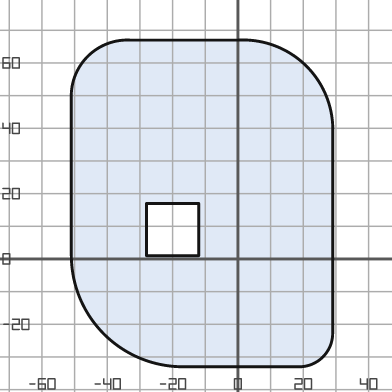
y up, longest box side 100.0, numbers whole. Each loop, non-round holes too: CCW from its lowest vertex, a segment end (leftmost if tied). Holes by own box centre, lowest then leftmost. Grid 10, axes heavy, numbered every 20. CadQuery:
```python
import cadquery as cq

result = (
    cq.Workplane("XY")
    .moveTo(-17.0, -33.0)
    .lineTo(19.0, -33.0)
    .threePointArc((26.0, -30.0), (29.0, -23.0))
    .lineTo(29.0, 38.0)
    .threePointArc((21.0, 59.0), (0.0, 67.0))
    .lineTo(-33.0, 67.0)
    .threePointArc((-46.0, 62.0), (-51.0, 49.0))
    .lineTo(-51.0, 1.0)
    .threePointArc((-41.0, -23.0), (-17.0, -33.0))
    .close()
    .moveTo(-28.0, 1.0)
    .lineTo(-12.0, 1.0)
    .lineTo(-12.0, 17.0)
    .lineTo(-28.0, 17.0)
    .close()
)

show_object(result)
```